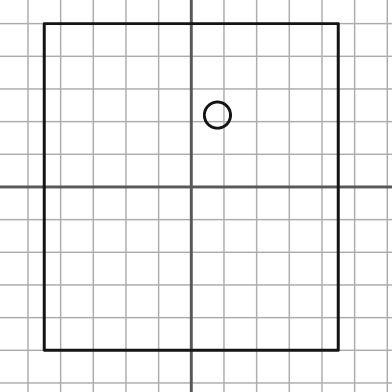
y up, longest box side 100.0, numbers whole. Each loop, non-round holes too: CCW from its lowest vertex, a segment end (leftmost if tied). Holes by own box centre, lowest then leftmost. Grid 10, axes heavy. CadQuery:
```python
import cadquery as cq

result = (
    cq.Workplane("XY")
    .moveTo(-45.0, -50.0)
    .lineTo(45.0, -50.0)
    .lineTo(45.0, 50.0)
    .lineTo(-45.0, 50.0)
    .close()
    .moveTo(8.0, 22.0)
    .circle(4.0)
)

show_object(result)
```